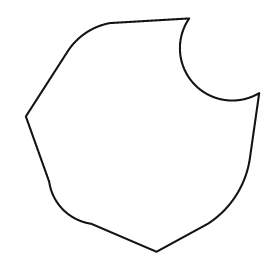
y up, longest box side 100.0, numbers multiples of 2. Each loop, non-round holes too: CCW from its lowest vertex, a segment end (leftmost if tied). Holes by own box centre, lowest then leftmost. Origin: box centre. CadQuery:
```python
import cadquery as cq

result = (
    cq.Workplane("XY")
    .moveTo(6.0, -50.0)
    .lineTo(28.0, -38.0)
    .threePointArc((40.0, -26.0), (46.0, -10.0))
    .lineTo(50.0, 18.0)
    .threePointArc((22.0, 22.0), (20.0, 50.0))
    .lineTo(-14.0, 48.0)
    .threePointArc((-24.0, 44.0), (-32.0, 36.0))
    .lineTo(-50.0, 8.0)
    .lineTo(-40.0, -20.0)
    .threePointArc((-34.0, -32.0), (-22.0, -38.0))
    .close()
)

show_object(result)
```